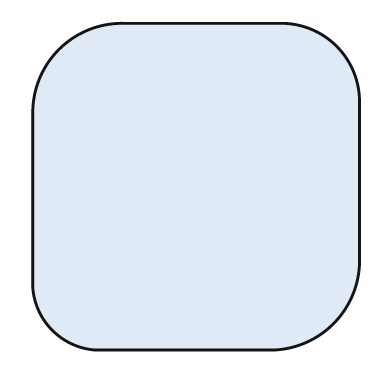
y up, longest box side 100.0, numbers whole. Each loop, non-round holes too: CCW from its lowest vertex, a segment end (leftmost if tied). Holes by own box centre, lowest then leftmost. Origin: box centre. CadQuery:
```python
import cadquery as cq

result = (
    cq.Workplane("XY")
    .moveTo(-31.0, -50.0)
    .lineTo(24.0, -50.0)
    .threePointArc((42.0, -42.0), (50.0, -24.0))
    .lineTo(50.0, 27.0)
    .threePointArc((43.0, 43.0), (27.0, 50.0))
    .lineTo(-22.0, 50.0)
    .threePointArc((-42.0, 42.0), (-50.0, 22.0))
    .lineTo(-50.0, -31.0)
    .threePointArc((-44.0, -44.0), (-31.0, -50.0))
    .close()
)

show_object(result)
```